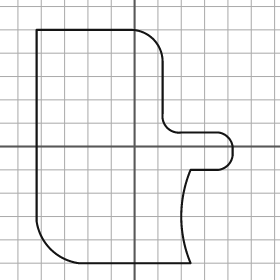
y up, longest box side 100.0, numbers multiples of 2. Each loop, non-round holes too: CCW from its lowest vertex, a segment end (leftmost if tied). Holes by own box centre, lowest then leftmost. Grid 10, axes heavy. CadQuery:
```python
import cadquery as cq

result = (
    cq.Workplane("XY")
    .moveTo(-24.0, -50.0)
    .lineTo(24.0, -50.0)
    .threePointArc((20.0, -30.0), (24.0, -10.0))
    .lineTo(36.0, -10.0)
    .threePointArc((40.0, -8.0), (42.0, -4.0))
    .lineTo(42.0, 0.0)
    .threePointArc((40.0, 4.0), (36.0, 6.0))
    .lineTo(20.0, 6.0)
    .threePointArc((14.0, 8.0), (12.0, 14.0))
    .lineTo(12.0, 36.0)
    .threePointArc((8.0, 46.0), (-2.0, 50.0))
    .lineTo(-42.0, 50.0)
    .lineTo(-42.0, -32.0)
    .threePointArc((-36.0, -44.0), (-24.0, -50.0))
    .close()
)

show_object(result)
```